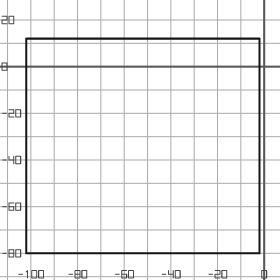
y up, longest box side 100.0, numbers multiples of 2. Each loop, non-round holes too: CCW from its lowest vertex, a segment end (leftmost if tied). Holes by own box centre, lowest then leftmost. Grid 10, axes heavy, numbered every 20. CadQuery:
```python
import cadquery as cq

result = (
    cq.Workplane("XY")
    .moveTo(-102.0, -80.0)
    .lineTo(-2.0, -80.0)
    .lineTo(-2.0, 12.0)
    .lineTo(-102.0, 12.0)
    .close()
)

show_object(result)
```